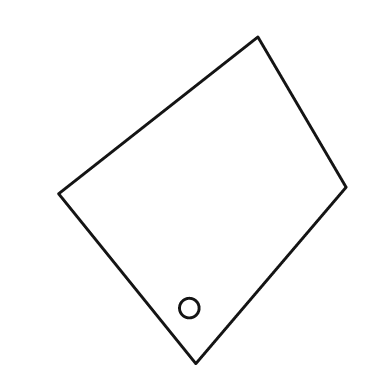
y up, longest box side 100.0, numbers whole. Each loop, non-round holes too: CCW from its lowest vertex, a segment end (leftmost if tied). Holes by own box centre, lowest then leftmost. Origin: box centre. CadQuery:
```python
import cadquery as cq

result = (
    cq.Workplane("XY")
    .moveTo(-2.0, -50.0)
    .lineTo(44.0, 4.0)
    .lineTo(17.0, 50.0)
    .lineTo(-44.0, 2.0)
    .close()
    .moveTo(-4.0, -33.0)
    .circle(3.0)
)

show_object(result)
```